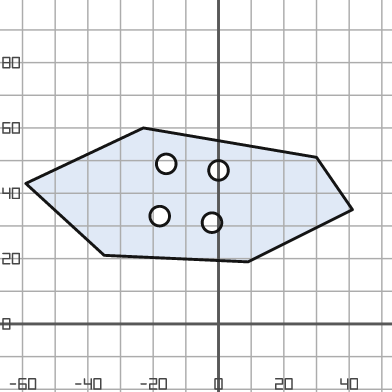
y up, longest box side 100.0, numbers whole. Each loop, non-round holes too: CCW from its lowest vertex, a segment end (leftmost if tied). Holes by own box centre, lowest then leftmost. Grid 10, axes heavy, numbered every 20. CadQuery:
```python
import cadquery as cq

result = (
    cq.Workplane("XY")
    .moveTo(9.0, 19.0)
    .lineTo(41.0, 35.0)
    .lineTo(30.0, 51.0)
    .lineTo(-23.0, 60.0)
    .lineTo(-59.0, 43.0)
    .lineTo(-35.0, 21.0)
    .close()
    .moveTo(-2.0, 31.0)
    .circle(3.0)
    .moveTo(-18.0, 33.0)
    .circle(3.0)
    .moveTo(0.0, 47.0)
    .circle(3.0)
    .moveTo(-16.0, 49.0)
    .circle(3.0)
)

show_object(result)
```